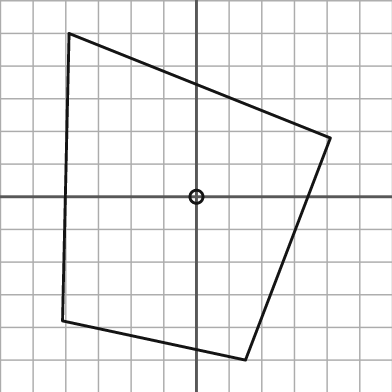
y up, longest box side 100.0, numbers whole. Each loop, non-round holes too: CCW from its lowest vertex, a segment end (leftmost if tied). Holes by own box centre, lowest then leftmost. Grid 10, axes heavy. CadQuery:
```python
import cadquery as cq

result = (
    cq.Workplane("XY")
    .moveTo(15.0, -50.0)
    .lineTo(41.0, 18.0)
    .lineTo(-39.0, 50.0)
    .lineTo(-41.0, -38.0)
    .close()
    .moveTo(0.0, 0.0)
    .circle(2.0)
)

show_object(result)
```